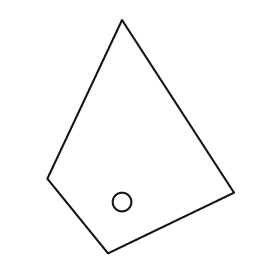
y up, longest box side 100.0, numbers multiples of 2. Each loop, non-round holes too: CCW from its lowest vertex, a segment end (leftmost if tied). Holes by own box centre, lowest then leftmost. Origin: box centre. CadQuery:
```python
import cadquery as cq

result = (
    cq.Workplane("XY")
    .moveTo(-14.0, -50.0)
    .lineTo(40.0, -24.0)
    .lineTo(-8.0, 50.0)
    .lineTo(-40.0, -18.0)
    .close()
    .moveTo(-8.0, -28.0)
    .circle(4.0)
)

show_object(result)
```